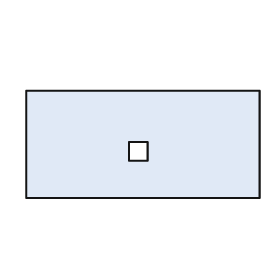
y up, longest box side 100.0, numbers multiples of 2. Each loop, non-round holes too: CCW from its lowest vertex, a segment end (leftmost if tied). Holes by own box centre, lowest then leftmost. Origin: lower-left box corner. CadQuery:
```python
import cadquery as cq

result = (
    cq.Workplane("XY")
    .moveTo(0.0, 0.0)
    .lineTo(100.0, 0.0)
    .lineTo(100.0, 46.0)
    .lineTo(0.0, 46.0)
    .close()
    .moveTo(44.0, 16.0)
    .lineTo(52.0, 16.0)
    .lineTo(52.0, 24.0)
    .lineTo(44.0, 24.0)
    .close()
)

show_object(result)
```